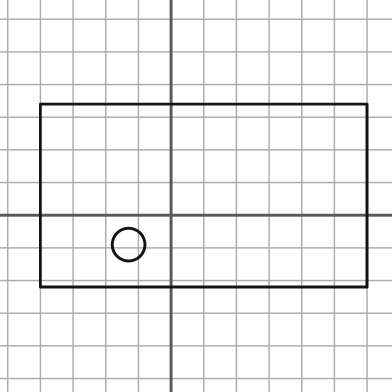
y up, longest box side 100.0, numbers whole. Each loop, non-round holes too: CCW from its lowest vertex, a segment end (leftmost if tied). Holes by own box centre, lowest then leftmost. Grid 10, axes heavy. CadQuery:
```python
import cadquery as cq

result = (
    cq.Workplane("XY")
    .moveTo(-40.0, -22.0)
    .lineTo(60.0, -22.0)
    .lineTo(60.0, 34.0)
    .lineTo(-40.0, 34.0)
    .close()
    .moveTo(-13.0, -9.0)
    .circle(5.0)
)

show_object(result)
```